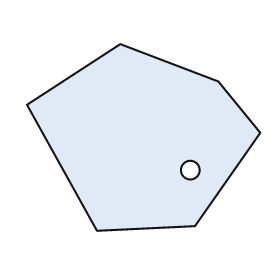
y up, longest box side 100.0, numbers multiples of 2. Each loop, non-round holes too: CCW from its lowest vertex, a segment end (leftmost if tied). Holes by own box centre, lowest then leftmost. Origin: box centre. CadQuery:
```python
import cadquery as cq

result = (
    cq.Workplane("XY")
    .moveTo(-20.0, -40.0)
    .lineTo(22.0, -38.0)
    .lineTo(50.0, 2.0)
    .lineTo(32.0, 24.0)
    .lineTo(-10.0, 40.0)
    .lineTo(-50.0, 14.0)
    .close()
    .moveTo(20.0, -14.0)
    .circle(4.0)
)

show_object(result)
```